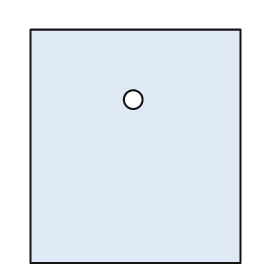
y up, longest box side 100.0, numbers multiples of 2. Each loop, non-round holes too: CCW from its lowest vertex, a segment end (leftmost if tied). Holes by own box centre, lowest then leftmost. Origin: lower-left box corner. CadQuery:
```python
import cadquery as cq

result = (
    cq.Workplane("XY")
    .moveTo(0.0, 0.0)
    .lineTo(90.0, 0.0)
    .lineTo(90.0, 100.0)
    .lineTo(0.0, 100.0)
    .close()
    .moveTo(44.0, 70.0)
    .circle(4.0)
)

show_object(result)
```